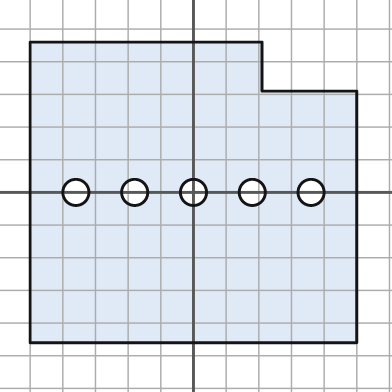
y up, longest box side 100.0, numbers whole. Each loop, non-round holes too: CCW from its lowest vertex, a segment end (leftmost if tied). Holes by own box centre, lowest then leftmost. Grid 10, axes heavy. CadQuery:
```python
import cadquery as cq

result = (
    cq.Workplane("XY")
    .moveTo(-50.0, -46.0)
    .lineTo(50.0, -46.0)
    .lineTo(50.0, 31.0)
    .lineTo(21.0, 31.0)
    .lineTo(21.0, 46.0)
    .lineTo(-50.0, 46.0)
    .close()
    .moveTo(-36.0, 0.0)
    .circle(4.0)
    .moveTo(-18.0, 0.0)
    .circle(4.0)
    .moveTo(0.0, 0.0)
    .circle(4.0)
    .moveTo(18.0, 0.0)
    .circle(4.0)
    .moveTo(36.0, 0.0)
    .circle(4.0)
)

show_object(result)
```